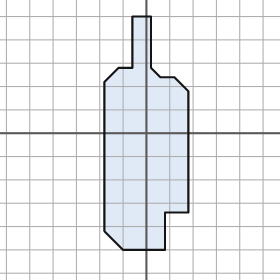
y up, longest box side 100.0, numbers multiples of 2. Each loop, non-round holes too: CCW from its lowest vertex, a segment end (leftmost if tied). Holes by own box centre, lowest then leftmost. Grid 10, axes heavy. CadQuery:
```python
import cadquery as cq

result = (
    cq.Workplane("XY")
    .moveTo(-10.0, -50.0)
    .lineTo(8.0, -50.0)
    .lineTo(8.0, -34.0)
    .lineTo(18.0, -34.0)
    .lineTo(18.0, 18.0)
    .lineTo(12.0, 24.0)
    .lineTo(6.0, 24.0)
    .lineTo(2.0, 28.0)
    .lineTo(2.0, 50.0)
    .lineTo(-6.0, 50.0)
    .lineTo(-6.0, 28.0)
    .lineTo(-12.0, 28.0)
    .lineTo(-18.0, 22.0)
    .lineTo(-18.0, -42.0)
    .close()
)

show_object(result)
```